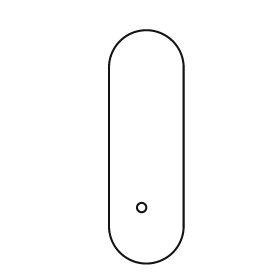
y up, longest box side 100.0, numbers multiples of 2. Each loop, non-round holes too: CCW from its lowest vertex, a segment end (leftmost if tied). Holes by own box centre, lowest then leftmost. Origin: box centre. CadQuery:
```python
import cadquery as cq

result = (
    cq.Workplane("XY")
    .moveTo(-16.0, -34.0)
    .threePointArc((0.0, -50.0), (16.0, -34.0))
    .lineTo(16.0, 34.0)
    .threePointArc((0.0, 50.0), (-16.0, 34.0))
    .close()
    .moveTo(-2.0, -26.0)
    .circle(2.0)
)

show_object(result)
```